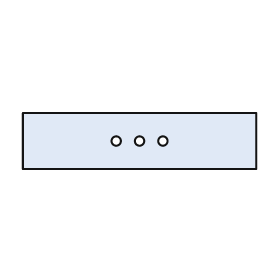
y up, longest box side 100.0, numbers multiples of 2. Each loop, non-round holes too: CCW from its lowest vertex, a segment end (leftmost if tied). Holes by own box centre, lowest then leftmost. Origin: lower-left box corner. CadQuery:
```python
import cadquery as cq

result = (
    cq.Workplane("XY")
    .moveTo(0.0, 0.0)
    .lineTo(100.0, 0.0)
    .lineTo(100.0, 24.0)
    .lineTo(0.0, 24.0)
    .close()
    .moveTo(40.0, 12.0)
    .circle(2.0)
    .moveTo(50.0, 12.0)
    .circle(2.0)
    .moveTo(60.0, 12.0)
    .circle(2.0)
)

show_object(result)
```